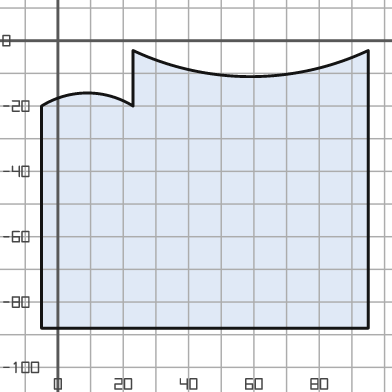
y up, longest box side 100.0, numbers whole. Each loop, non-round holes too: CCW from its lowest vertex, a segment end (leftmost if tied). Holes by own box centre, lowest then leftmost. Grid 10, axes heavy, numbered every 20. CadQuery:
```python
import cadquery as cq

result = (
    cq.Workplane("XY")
    .moveTo(-5.0, -88.0)
    .lineTo(95.0, -88.0)
    .lineTo(95.0, -3.0)
    .threePointArc((59.0, -11.0), (23.0, -3.0))
    .lineTo(23.0, -20.0)
    .threePointArc((9.0, -16.0), (-5.0, -20.0))
    .close()
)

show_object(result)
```